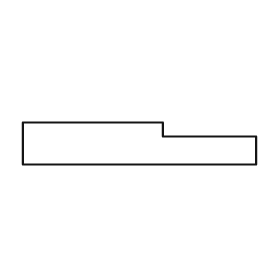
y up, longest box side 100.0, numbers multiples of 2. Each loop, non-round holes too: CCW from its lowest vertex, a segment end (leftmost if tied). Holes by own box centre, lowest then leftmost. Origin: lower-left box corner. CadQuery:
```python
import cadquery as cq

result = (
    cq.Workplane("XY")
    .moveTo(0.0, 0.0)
    .lineTo(100.0, 0.0)
    .lineTo(100.0, 12.0)
    .lineTo(60.0, 12.0)
    .lineTo(60.0, 18.0)
    .lineTo(0.0, 18.0)
    .close()
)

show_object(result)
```